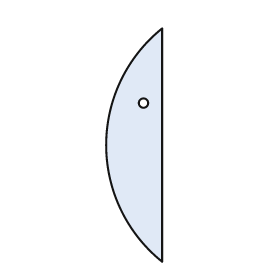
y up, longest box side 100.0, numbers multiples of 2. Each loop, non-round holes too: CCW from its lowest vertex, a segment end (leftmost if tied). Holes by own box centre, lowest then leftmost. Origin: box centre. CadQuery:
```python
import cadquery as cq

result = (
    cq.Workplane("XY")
    .moveTo(12.0, -50.0)
    .lineTo(12.0, 50.0)
    .threePointArc((-12.0, 0.0), (12.0, -50.0))
    .close()
    .moveTo(4.0, 18.0)
    .circle(2.0)
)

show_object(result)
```